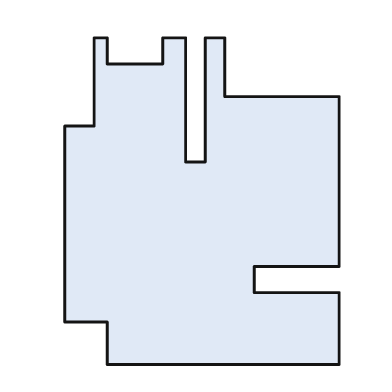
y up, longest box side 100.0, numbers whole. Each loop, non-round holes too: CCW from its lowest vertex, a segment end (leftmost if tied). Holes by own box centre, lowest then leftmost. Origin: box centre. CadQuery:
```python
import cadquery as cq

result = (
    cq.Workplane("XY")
    .moveTo(-29.0, -50.0)
    .lineTo(42.0, -50.0)
    .lineTo(42.0, -28.0)
    .lineTo(16.0, -28.0)
    .lineTo(16.0, -20.0)
    .lineTo(42.0, -20.0)
    .lineTo(42.0, 32.0)
    .lineTo(7.0, 32.0)
    .lineTo(7.0, 50.0)
    .lineTo(1.0, 50.0)
    .lineTo(1.0, 12.0)
    .lineTo(-5.0, 12.0)
    .lineTo(-5.0, 50.0)
    .lineTo(-12.0, 50.0)
    .lineTo(-12.0, 42.0)
    .lineTo(-29.0, 42.0)
    .lineTo(-29.0, 50.0)
    .lineTo(-33.0, 50.0)
    .lineTo(-33.0, 23.0)
    .lineTo(-42.0, 23.0)
    .lineTo(-42.0, -37.0)
    .lineTo(-29.0, -37.0)
    .close()
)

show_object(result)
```